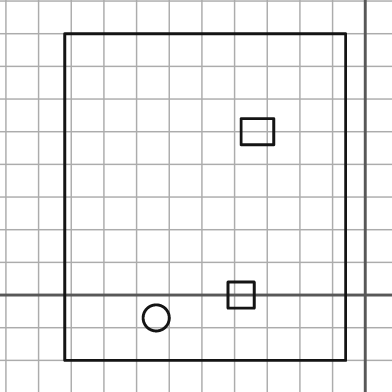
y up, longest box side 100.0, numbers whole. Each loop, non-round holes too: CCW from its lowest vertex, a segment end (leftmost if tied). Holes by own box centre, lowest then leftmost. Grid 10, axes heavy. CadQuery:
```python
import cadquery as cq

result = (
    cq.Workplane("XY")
    .moveTo(-92.0, -20.0)
    .lineTo(-6.0, -20.0)
    .lineTo(-6.0, 80.0)
    .lineTo(-92.0, 80.0)
    .close()
    .moveTo(-64.0, -7.0)
    .circle(4.0)
    .moveTo(-42.0, -4.0)
    .lineTo(-34.0, -4.0)
    .lineTo(-34.0, 4.0)
    .lineTo(-42.0, 4.0)
    .close()
    .moveTo(-38.0, 46.0)
    .lineTo(-28.0, 46.0)
    .lineTo(-28.0, 54.0)
    .lineTo(-38.0, 54.0)
    .close()
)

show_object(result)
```